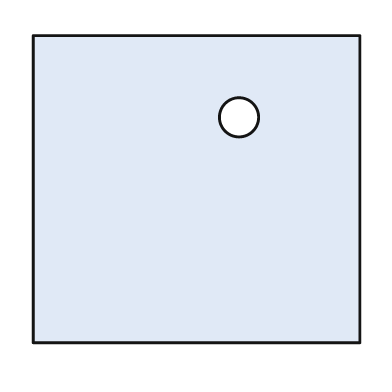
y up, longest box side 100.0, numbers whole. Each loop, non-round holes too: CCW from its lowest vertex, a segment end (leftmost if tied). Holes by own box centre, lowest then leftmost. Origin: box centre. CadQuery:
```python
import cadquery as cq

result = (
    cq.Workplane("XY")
    .moveTo(-50.0, -47.0)
    .lineTo(50.0, -47.0)
    .lineTo(50.0, 47.0)
    .lineTo(-50.0, 47.0)
    .close()
    .moveTo(13.0, 22.0)
    .circle(6.0)
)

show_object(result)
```